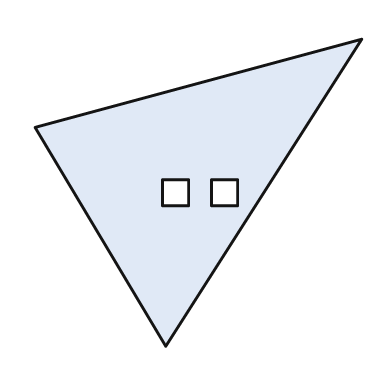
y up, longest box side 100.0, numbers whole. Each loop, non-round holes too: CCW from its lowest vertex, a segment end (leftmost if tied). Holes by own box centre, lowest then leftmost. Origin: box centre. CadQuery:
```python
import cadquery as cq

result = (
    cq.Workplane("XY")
    .moveTo(-10.0, -47.0)
    .lineTo(50.0, 47.0)
    .lineTo(-50.0, 20.0)
    .close()
    .moveTo(-11.0, -4.0)
    .lineTo(-3.0, -4.0)
    .lineTo(-3.0, 4.0)
    .lineTo(-11.0, 4.0)
    .close()
    .moveTo(4.0, -4.0)
    .lineTo(12.0, -4.0)
    .lineTo(12.0, 4.0)
    .lineTo(4.0, 4.0)
    .close()
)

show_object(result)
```